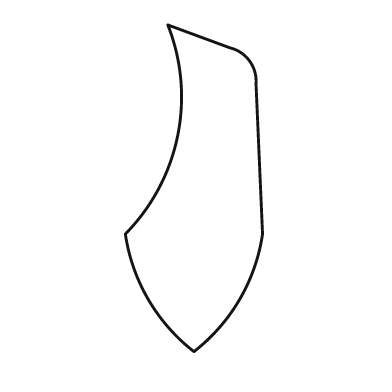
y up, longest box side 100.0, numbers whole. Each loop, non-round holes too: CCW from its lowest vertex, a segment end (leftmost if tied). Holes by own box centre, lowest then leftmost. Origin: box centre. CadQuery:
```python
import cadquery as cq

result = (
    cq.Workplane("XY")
    .moveTo(0.0, -50.0)
    .threePointArc((14.0, -34.0), (21.0, -14.0))
    .lineTo(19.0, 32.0)
    .threePointArc((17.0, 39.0), (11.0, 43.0))
    .lineTo(-8.0, 50.0)
    .threePointArc((-5.0, 16.0), (-21.0, -14.0))
    .threePointArc((-14.0, -34.0), (0.0, -50.0))
    .close()
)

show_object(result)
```